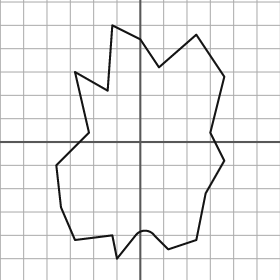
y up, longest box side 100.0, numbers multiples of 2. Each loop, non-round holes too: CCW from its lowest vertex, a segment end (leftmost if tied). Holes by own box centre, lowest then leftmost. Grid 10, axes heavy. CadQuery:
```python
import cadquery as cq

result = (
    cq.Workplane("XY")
    .moveTo(-10.0, -50.0)
    .lineTo(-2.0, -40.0)
    .threePointArc((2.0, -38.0), (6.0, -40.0))
    .lineTo(12.0, -46.0)
    .lineTo(24.0, -42.0)
    .lineTo(28.0, -22.0)
    .lineTo(36.0, -8.0)
    .lineTo(30.0, 4.0)
    .lineTo(36.0, 28.0)
    .lineTo(24.0, 46.0)
    .lineTo(8.0, 32.0)
    .lineTo(0.0, 44.0)
    .lineTo(-12.0, 50.0)
    .lineTo(-14.0, 22.0)
    .lineTo(-28.0, 30.0)
    .lineTo(-22.0, 4.0)
    .lineTo(-36.0, -10.0)
    .lineTo(-34.0, -28.0)
    .lineTo(-28.0, -42.0)
    .lineTo(-12.0, -40.0)
    .close()
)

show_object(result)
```